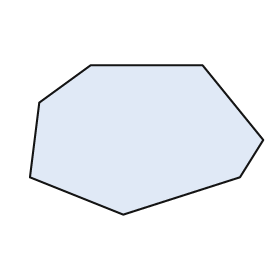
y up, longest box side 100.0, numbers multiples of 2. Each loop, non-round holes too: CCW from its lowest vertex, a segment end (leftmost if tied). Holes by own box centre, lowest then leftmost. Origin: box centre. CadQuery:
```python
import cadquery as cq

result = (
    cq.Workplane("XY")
    .moveTo(-10.0, -32.0)
    .lineTo(40.0, -16.0)
    .lineTo(50.0, 0.0)
    .lineTo(24.0, 32.0)
    .lineTo(-24.0, 32.0)
    .lineTo(-46.0, 16.0)
    .lineTo(-50.0, -16.0)
    .close()
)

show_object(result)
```